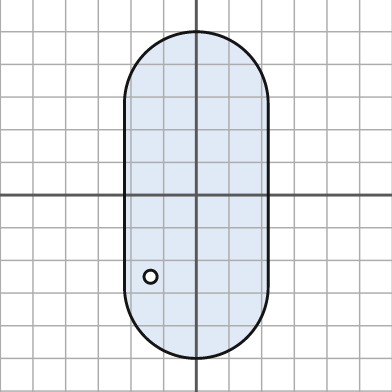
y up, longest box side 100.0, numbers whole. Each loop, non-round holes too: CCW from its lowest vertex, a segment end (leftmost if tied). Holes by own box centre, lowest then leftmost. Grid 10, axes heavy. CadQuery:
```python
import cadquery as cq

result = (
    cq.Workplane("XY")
    .moveTo(-22.0, -28.0)
    .threePointArc((0.0, -50.0), (22.0, -28.0))
    .lineTo(22.0, 28.0)
    .threePointArc((0.0, 50.0), (-22.0, 28.0))
    .close()
    .moveTo(-14.0, -25.0)
    .circle(2.0)
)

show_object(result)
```